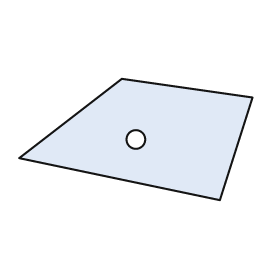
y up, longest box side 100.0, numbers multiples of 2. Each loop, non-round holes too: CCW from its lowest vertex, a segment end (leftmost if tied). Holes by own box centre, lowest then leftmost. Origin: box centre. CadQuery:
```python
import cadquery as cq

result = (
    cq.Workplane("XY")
    .moveTo(36.0, -26.0)
    .lineTo(50.0, 18.0)
    .lineTo(-6.0, 26.0)
    .lineTo(-50.0, -8.0)
    .close()
    .moveTo(0.0, 0.0)
    .circle(4.0)
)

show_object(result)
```